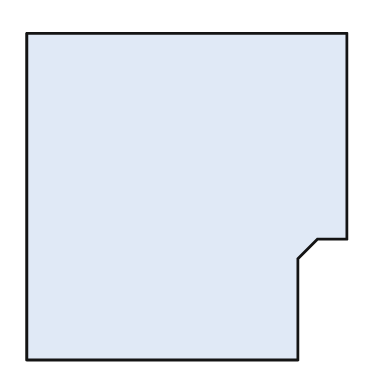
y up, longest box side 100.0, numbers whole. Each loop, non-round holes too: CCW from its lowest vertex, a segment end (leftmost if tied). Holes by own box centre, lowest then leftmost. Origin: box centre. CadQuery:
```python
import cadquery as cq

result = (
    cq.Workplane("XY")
    .moveTo(-49.0, -50.0)
    .lineTo(34.0, -50.0)
    .lineTo(34.0, -19.0)
    .lineTo(40.0, -13.0)
    .lineTo(49.0, -13.0)
    .lineTo(49.0, 50.0)
    .lineTo(-49.0, 50.0)
    .close()
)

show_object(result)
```